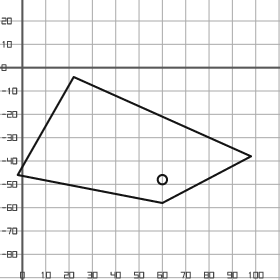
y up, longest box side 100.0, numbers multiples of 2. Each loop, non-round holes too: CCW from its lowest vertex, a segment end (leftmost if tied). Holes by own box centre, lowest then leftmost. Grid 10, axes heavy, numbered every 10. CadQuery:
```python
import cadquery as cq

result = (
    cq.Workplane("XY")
    .moveTo(60.0, -58.0)
    .lineTo(98.0, -38.0)
    .lineTo(22.0, -4.0)
    .lineTo(-2.0, -46.0)
    .close()
    .moveTo(60.0, -48.0)
    .circle(2.0)
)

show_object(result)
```